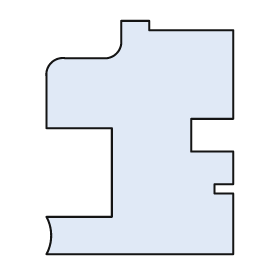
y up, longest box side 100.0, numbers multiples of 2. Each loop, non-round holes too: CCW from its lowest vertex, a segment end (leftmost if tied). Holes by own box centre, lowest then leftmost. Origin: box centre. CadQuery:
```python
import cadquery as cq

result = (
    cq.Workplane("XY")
    .moveTo(-40.0, -50.0)
    .lineTo(40.0, -50.0)
    .lineTo(40.0, -24.0)
    .lineTo(32.0, -24.0)
    .lineTo(32.0, -20.0)
    .lineTo(40.0, -20.0)
    .lineTo(40.0, -6.0)
    .lineTo(22.0, -6.0)
    .lineTo(22.0, 8.0)
    .lineTo(40.0, 8.0)
    .lineTo(40.0, 46.0)
    .lineTo(4.0, 46.0)
    .lineTo(4.0, 50.0)
    .lineTo(-8.0, 50.0)
    .lineTo(-8.0, 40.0)
    .threePointArc((-10.0, 36.0), (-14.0, 34.0))
    .lineTo(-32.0, 34.0)
    .threePointArc((-38.0, 32.0), (-40.0, 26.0))
    .lineTo(-40.0, 4.0)
    .lineTo(-12.0, 4.0)
    .lineTo(-12.0, -34.0)
    .lineTo(-40.0, -34.0)
    .threePointArc((-38.0, -42.0), (-40.0, -50.0))
    .close()
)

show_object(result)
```